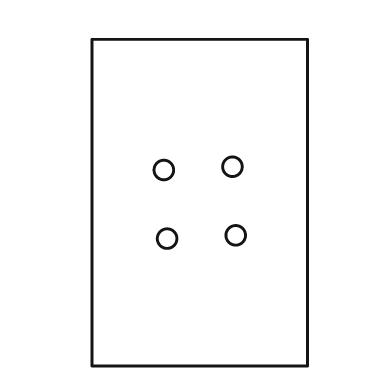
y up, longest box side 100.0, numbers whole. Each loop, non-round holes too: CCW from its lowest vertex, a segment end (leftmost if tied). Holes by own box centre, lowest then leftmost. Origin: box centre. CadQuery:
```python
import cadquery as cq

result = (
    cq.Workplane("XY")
    .moveTo(-33.0, -50.0)
    .lineTo(33.0, -50.0)
    .lineTo(33.0, 50.0)
    .lineTo(-33.0, 50.0)
    .close()
    .moveTo(-10.0, -11.0)
    .circle(3.0)
    .moveTo(11.0, -10.0)
    .circle(3.0)
    .moveTo(-11.0, 10.0)
    .circle(3.0)
    .moveTo(10.0, 11.0)
    .circle(3.0)
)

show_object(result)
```